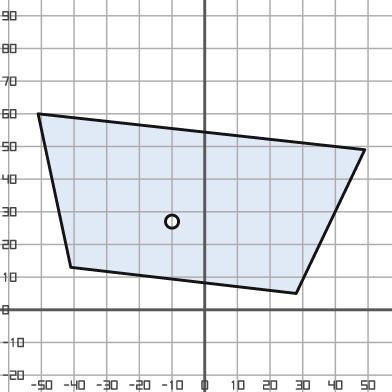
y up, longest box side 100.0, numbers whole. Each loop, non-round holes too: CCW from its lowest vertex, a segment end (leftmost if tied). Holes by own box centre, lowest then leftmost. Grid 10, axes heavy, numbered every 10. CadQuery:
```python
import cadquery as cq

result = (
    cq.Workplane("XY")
    .moveTo(28.0, 5.0)
    .lineTo(49.0, 49.0)
    .lineTo(-51.0, 60.0)
    .lineTo(-41.0, 13.0)
    .close()
    .moveTo(-10.0, 27.0)
    .circle(2.0)
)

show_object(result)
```